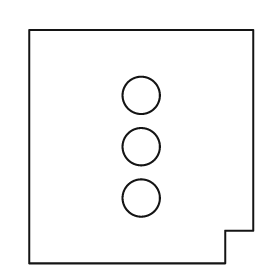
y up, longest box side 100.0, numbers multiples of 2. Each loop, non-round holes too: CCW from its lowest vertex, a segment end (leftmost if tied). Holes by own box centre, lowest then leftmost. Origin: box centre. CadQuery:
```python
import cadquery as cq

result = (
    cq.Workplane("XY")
    .moveTo(-48.0, -50.0)
    .lineTo(36.0, -50.0)
    .lineTo(36.0, -36.0)
    .lineTo(48.0, -36.0)
    .lineTo(48.0, 50.0)
    .lineTo(-48.0, 50.0)
    .close()
    .moveTo(0.0, -22.0)
    .circle(8.0)
    .moveTo(0.0, 0.0)
    .circle(8.0)
    .moveTo(0.0, 22.0)
    .circle(8.0)
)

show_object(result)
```